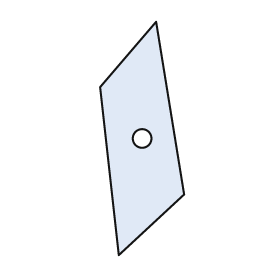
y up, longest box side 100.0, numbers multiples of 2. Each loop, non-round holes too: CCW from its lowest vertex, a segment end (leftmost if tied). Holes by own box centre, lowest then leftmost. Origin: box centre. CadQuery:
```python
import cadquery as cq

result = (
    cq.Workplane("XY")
    .moveTo(-10.0, -50.0)
    .lineTo(18.0, -24.0)
    .lineTo(6.0, 50.0)
    .lineTo(-18.0, 22.0)
    .close()
    .moveTo(0.0, 0.0)
    .circle(4.0)
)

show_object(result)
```